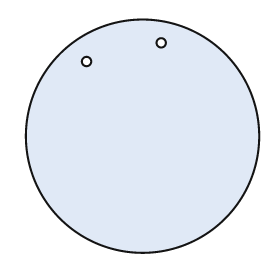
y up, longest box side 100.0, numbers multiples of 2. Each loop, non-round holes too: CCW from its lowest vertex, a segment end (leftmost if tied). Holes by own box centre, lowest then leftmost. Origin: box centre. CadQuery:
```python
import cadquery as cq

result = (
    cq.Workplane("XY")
    .moveTo(0.0, 0.0)
    .circle(50.0)
    .moveTo(-24.0, 32.0)
    .circle(2.0)
    .moveTo(8.0, 40.0)
    .circle(2.0)
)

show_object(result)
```